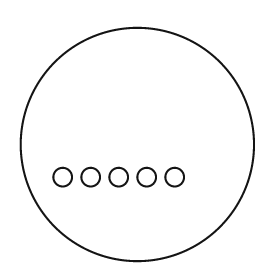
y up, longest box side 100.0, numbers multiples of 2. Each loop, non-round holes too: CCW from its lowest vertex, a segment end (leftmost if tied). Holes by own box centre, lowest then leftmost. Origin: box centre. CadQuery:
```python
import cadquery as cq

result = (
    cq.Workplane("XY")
    .moveTo(0.0, 0.0)
    .circle(50.0)
    .moveTo(-32.0, -14.0)
    .circle(4.0)
    .moveTo(-20.0, -14.0)
    .circle(4.0)
    .moveTo(-8.0, -14.0)
    .circle(4.0)
    .moveTo(4.0, -14.0)
    .circle(4.0)
    .moveTo(16.0, -14.0)
    .circle(4.0)
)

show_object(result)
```